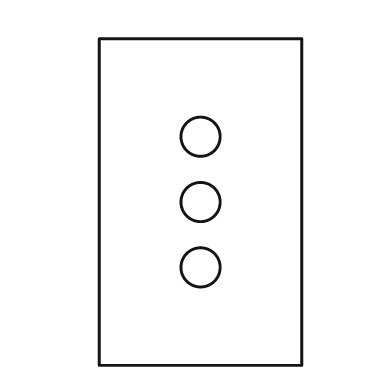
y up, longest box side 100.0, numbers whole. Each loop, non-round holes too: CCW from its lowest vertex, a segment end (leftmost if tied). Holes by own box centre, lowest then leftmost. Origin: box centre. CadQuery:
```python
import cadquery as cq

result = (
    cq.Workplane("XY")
    .moveTo(-31.0, -50.0)
    .lineTo(31.0, -50.0)
    .lineTo(31.0, 50.0)
    .lineTo(-31.0, 50.0)
    .close()
    .moveTo(0.0, -20.0)
    .circle(6.0)
    .moveTo(0.0, 0.0)
    .circle(6.0)
    .moveTo(0.0, 20.0)
    .circle(6.0)
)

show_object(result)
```